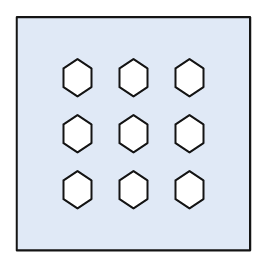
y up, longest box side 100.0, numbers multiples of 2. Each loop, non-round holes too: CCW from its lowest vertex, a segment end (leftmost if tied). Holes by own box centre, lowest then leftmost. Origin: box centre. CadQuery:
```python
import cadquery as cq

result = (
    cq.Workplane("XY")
    .moveTo(-50.0, -50.0)
    .lineTo(50.0, -50.0)
    .lineTo(50.0, 50.0)
    .lineTo(-50.0, 50.0)
    .close()
    .moveTo(-24.0, -32.0)
    .lineTo(-18.0, -28.0)
    .lineTo(-18.0, -20.0)
    .lineTo(-24.0, -16.0)
    .lineTo(-30.0, -20.0)
    .lineTo(-30.0, -28.0)
    .close()
    .moveTo(0.0, -32.0)
    .lineTo(6.0, -28.0)
    .lineTo(6.0, -20.0)
    .lineTo(0.0, -16.0)
    .lineTo(-6.0, -20.0)
    .lineTo(-6.0, -28.0)
    .close()
    .moveTo(24.0, -32.0)
    .lineTo(30.0, -28.0)
    .lineTo(30.0, -20.0)
    .lineTo(24.0, -16.0)
    .lineTo(18.0, -20.0)
    .lineTo(18.0, -28.0)
    .close()
    .moveTo(-24.0, -8.0)
    .lineTo(-18.0, -4.0)
    .lineTo(-18.0, 4.0)
    .lineTo(-24.0, 8.0)
    .lineTo(-30.0, 4.0)
    .lineTo(-30.0, -4.0)
    .close()
    .moveTo(0.0, -8.0)
    .lineTo(6.0, -4.0)
    .lineTo(6.0, 4.0)
    .lineTo(0.0, 8.0)
    .lineTo(-6.0, 4.0)
    .lineTo(-6.0, -4.0)
    .close()
    .moveTo(24.0, -8.0)
    .lineTo(30.0, -4.0)
    .lineTo(30.0, 4.0)
    .lineTo(24.0, 8.0)
    .lineTo(18.0, 4.0)
    .lineTo(18.0, -4.0)
    .close()
    .moveTo(-24.0, 16.0)
    .lineTo(-18.0, 20.0)
    .lineTo(-18.0, 28.0)
    .lineTo(-24.0, 32.0)
    .lineTo(-30.0, 28.0)
    .lineTo(-30.0, 20.0)
    .close()
    .moveTo(0.0, 16.0)
    .lineTo(6.0, 20.0)
    .lineTo(6.0, 28.0)
    .lineTo(0.0, 32.0)
    .lineTo(-6.0, 28.0)
    .lineTo(-6.0, 20.0)
    .close()
    .moveTo(24.0, 16.0)
    .lineTo(30.0, 20.0)
    .lineTo(30.0, 28.0)
    .lineTo(24.0, 32.0)
    .lineTo(18.0, 28.0)
    .lineTo(18.0, 20.0)
    .close()
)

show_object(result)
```